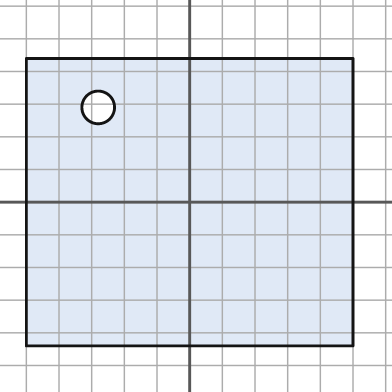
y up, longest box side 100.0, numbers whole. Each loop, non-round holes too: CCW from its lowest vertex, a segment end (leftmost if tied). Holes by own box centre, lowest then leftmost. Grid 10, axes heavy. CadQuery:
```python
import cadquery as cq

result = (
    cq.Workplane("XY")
    .moveTo(-50.0, -44.0)
    .lineTo(50.0, -44.0)
    .lineTo(50.0, 44.0)
    .lineTo(-50.0, 44.0)
    .close()
    .moveTo(-28.0, 29.0)
    .circle(5.0)
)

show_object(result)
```